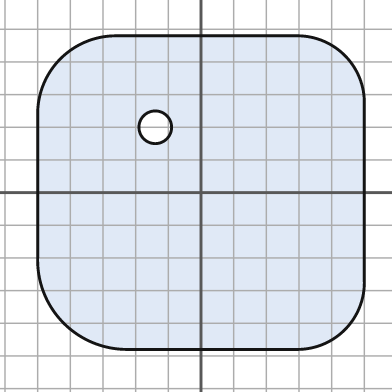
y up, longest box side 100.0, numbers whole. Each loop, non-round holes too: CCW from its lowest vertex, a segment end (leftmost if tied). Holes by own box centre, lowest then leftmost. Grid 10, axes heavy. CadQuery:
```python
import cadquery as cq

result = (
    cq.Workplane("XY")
    .moveTo(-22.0, -48.0)
    .lineTo(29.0, -48.0)
    .threePointArc((44.0, -42.0), (50.0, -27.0))
    .lineTo(50.0, 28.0)
    .threePointArc((44.0, 42.0), (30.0, 48.0))
    .lineTo(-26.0, 48.0)
    .threePointArc((-43.0, 41.0), (-50.0, 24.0))
    .lineTo(-50.0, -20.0)
    .threePointArc((-42.0, -40.0), (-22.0, -48.0))
    .close()
    .moveTo(-14.0, 20.0)
    .circle(5.0)
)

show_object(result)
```